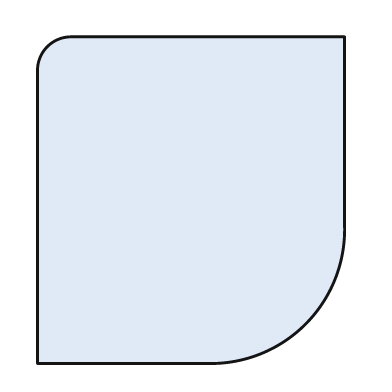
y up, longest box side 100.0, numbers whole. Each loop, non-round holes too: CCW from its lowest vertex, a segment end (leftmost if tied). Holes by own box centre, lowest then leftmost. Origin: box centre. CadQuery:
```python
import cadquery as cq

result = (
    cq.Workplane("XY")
    .moveTo(-47.0, -50.0)
    .lineTo(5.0, -50.0)
    .threePointArc((35.0, -38.0), (47.0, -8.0))
    .lineTo(47.0, 50.0)
    .lineTo(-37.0, 50.0)
    .threePointArc((-44.0, 47.0), (-47.0, 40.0))
    .close()
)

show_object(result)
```